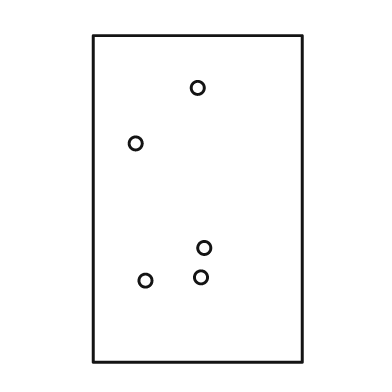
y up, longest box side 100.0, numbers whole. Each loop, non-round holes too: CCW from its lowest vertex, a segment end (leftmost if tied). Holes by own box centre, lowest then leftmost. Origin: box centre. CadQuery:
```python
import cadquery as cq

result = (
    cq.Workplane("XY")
    .moveTo(-32.0, -50.0)
    .lineTo(32.0, -50.0)
    .lineTo(32.0, 50.0)
    .lineTo(-32.0, 50.0)
    .close()
    .moveTo(-16.0, -25.0)
    .circle(2.0)
    .moveTo(1.0, -24.0)
    .circle(2.0)
    .moveTo(2.0, -15.0)
    .circle(2.0)
    .moveTo(-19.0, 17.0)
    .circle(2.0)
    .moveTo(0.0, 34.0)
    .circle(2.0)
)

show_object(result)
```